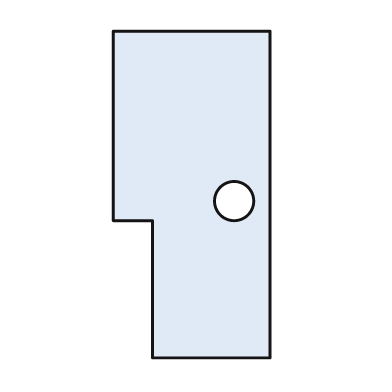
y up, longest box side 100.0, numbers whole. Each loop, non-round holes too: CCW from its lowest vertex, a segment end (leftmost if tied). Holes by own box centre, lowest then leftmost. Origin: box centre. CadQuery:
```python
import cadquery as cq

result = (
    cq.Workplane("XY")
    .moveTo(-12.0, -50.0)
    .lineTo(24.0, -50.0)
    .lineTo(24.0, 50.0)
    .lineTo(-24.0, 50.0)
    .lineTo(-24.0, -8.0)
    .lineTo(-12.0, -8.0)
    .close()
    .moveTo(13.0, -2.0)
    .circle(6.0)
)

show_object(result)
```